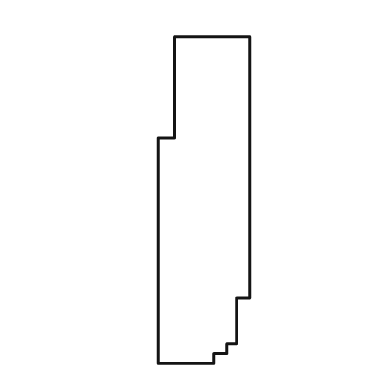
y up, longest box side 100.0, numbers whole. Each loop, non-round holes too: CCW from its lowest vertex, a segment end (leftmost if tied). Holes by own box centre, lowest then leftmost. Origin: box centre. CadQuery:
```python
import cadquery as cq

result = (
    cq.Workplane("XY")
    .moveTo(-14.0, -50.0)
    .lineTo(3.0, -50.0)
    .lineTo(3.0, -47.0)
    .lineTo(7.0, -47.0)
    .lineTo(7.0, -44.0)
    .lineTo(10.0, -44.0)
    .lineTo(10.0, -30.0)
    .lineTo(14.0, -30.0)
    .lineTo(14.0, 50.0)
    .lineTo(-9.0, 50.0)
    .lineTo(-9.0, 19.0)
    .lineTo(-14.0, 19.0)
    .close()
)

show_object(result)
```